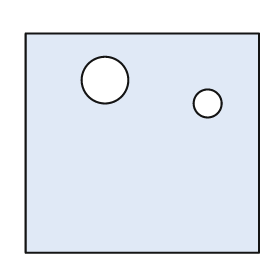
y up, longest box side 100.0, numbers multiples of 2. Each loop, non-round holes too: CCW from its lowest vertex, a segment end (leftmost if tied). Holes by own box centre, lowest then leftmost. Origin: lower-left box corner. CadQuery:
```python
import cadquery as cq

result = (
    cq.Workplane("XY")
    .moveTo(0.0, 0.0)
    .lineTo(100.0, 0.0)
    .lineTo(100.0, 94.0)
    .lineTo(0.0, 94.0)
    .close()
    .moveTo(78.0, 64.0)
    .circle(6.0)
    .moveTo(34.0, 74.0)
    .circle(10.0)
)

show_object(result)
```